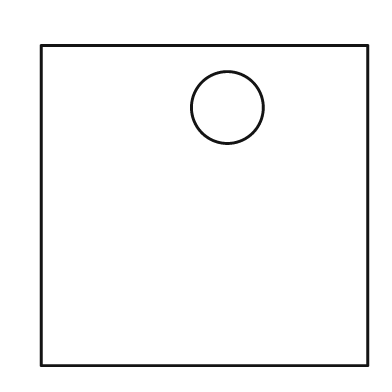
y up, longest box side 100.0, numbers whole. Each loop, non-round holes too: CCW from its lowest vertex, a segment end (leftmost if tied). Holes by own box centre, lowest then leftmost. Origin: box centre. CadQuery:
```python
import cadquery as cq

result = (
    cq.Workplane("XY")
    .moveTo(-50.0, -49.0)
    .lineTo(50.0, -49.0)
    .lineTo(50.0, 49.0)
    .lineTo(-50.0, 49.0)
    .close()
    .moveTo(7.0, 30.0)
    .circle(11.0)
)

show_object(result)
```